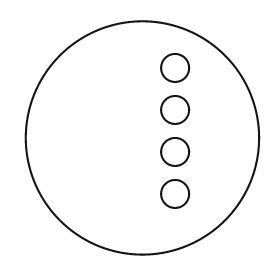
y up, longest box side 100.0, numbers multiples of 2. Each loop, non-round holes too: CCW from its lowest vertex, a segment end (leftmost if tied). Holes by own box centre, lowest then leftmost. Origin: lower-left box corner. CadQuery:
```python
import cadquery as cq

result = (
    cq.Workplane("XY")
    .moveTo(50.0, 50.0)
    .circle(50.0)
    .moveTo(64.0, 26.0)
    .circle(6.0)
    .moveTo(64.0, 44.0)
    .circle(6.0)
    .moveTo(64.0, 62.0)
    .circle(6.0)
    .moveTo(64.0, 80.0)
    .circle(6.0)
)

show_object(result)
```